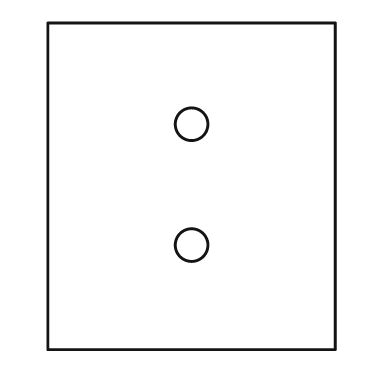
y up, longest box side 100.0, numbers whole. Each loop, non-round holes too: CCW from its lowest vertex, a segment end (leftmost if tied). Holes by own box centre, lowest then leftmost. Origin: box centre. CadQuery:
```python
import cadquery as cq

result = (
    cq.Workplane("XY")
    .moveTo(-44.0, -50.0)
    .lineTo(44.0, -50.0)
    .lineTo(44.0, 50.0)
    .lineTo(-44.0, 50.0)
    .close()
    .moveTo(0.0, -18.0)
    .circle(5.0)
    .moveTo(0.0, 19.0)
    .circle(5.0)
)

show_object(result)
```